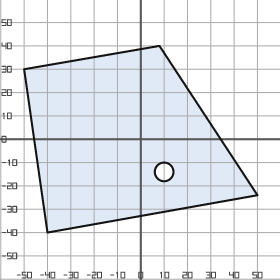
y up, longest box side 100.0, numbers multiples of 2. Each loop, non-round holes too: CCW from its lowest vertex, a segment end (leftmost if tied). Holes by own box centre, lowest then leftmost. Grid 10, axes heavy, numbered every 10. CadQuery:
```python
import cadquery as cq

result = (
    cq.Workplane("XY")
    .moveTo(-40.0, -40.0)
    .lineTo(50.0, -24.0)
    .lineTo(8.0, 40.0)
    .lineTo(-50.0, 30.0)
    .close()
    .moveTo(10.0, -14.0)
    .circle(4.0)
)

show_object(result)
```